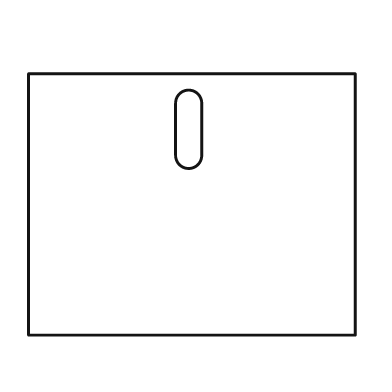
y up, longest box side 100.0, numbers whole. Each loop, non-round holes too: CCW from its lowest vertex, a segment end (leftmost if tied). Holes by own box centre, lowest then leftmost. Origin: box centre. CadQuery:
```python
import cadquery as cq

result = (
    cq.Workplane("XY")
    .moveTo(-50.0, -40.0)
    .lineTo(50.0, -40.0)
    .lineTo(50.0, 40.0)
    .lineTo(-50.0, 40.0)
    .close()
    .moveTo(-5.0, 15.0)
    .threePointArc((-1.0, 11.0), (3.0, 15.0))
    .lineTo(3.0, 31.0)
    .threePointArc((-1.0, 35.0), (-5.0, 31.0))
    .close()
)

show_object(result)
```